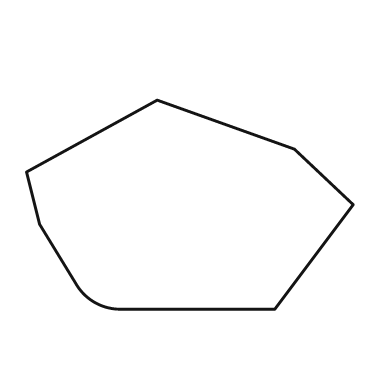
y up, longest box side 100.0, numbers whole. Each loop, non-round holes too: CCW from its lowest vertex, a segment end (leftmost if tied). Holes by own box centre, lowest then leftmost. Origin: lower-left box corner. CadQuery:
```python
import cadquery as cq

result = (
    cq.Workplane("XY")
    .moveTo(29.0, 0.0)
    .lineTo(76.0, 0.0)
    .lineTo(100.0, 32.0)
    .lineTo(82.0, 49.0)
    .lineTo(40.0, 64.0)
    .lineTo(0.0, 42.0)
    .lineTo(4.0, 26.0)
    .lineTo(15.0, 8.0)
    .threePointArc((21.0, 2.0), (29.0, 0.0))
    .close()
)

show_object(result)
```